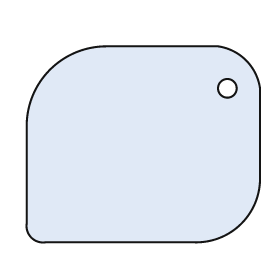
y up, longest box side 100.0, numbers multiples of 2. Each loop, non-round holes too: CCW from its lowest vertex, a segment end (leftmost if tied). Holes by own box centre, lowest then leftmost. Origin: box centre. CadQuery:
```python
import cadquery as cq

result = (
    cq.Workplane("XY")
    .moveTo(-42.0, -42.0)
    .lineTo(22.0, -42.0)
    .threePointArc((42.0, -34.0), (50.0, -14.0))
    .lineTo(50.0, 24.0)
    .threePointArc((44.0, 36.0), (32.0, 42.0))
    .lineTo(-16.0, 42.0)
    .threePointArc((-40.0, 32.0), (-50.0, 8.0))
    .lineTo(-50.0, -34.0)
    .threePointArc((-48.0, -40.0), (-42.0, -42.0))
    .close()
    .moveTo(36.0, 24.0)
    .circle(4.0)
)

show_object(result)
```